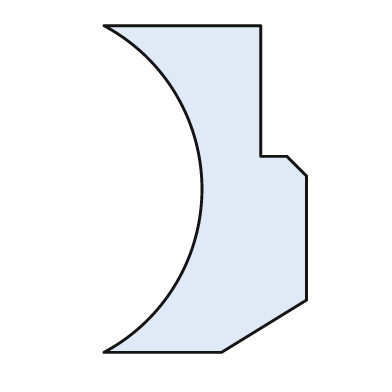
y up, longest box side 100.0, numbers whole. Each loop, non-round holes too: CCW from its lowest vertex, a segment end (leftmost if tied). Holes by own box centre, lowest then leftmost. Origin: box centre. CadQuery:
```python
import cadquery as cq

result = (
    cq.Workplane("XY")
    .moveTo(-31.0, -50.0)
    .lineTo(5.0, -50.0)
    .lineTo(31.0, -34.0)
    .lineTo(31.0, 4.0)
    .lineTo(25.0, 10.0)
    .lineTo(17.0, 10.0)
    .lineTo(17.0, 50.0)
    .lineTo(-31.0, 50.0)
    .threePointArc((-1.0, 0.0), (-31.0, -50.0))
    .close()
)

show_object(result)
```